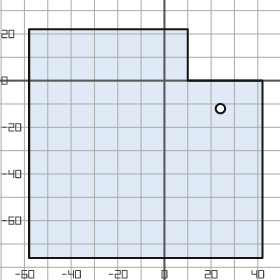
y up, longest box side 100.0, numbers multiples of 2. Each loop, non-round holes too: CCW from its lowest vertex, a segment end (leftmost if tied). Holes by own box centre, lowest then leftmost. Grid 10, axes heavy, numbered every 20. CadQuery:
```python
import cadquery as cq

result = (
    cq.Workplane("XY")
    .moveTo(-58.0, -76.0)
    .lineTo(42.0, -76.0)
    .lineTo(42.0, 0.0)
    .lineTo(10.0, 0.0)
    .lineTo(10.0, 22.0)
    .lineTo(-58.0, 22.0)
    .close()
    .moveTo(24.0, -12.0)
    .circle(2.0)
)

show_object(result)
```